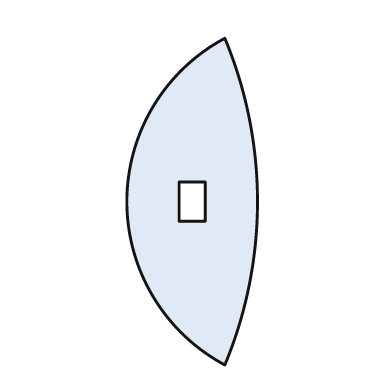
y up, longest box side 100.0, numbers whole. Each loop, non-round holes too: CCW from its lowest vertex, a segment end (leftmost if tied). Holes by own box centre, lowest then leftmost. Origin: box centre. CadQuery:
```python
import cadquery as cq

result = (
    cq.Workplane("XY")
    .moveTo(10.0, -50.0)
    .threePointArc((20.0, 0.0), (10.0, 50.0))
    .threePointArc((-20.0, 0.0), (10.0, -50.0))
    .close()
    .moveTo(-4.0, -6.0)
    .lineTo(4.0, -6.0)
    .lineTo(4.0, 6.0)
    .lineTo(-4.0, 6.0)
    .close()
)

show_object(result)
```